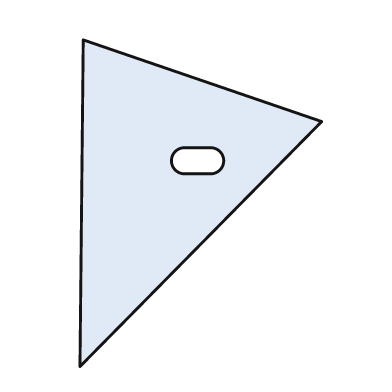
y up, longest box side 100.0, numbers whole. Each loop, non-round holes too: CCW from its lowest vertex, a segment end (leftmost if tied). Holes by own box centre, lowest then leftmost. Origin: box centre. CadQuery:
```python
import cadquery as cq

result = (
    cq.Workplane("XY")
    .moveTo(-37.0, -50.0)
    .lineTo(37.0, 25.0)
    .lineTo(-36.0, 50.0)
    .close()
    .moveTo(-5.0, 9.0)
    .lineTo(3.0, 9.0)
    .threePointArc((7.0, 13.0), (3.0, 17.0))
    .lineTo(-5.0, 17.0)
    .threePointArc((-9.0, 13.0), (-5.0, 9.0))
    .close()
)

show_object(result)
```